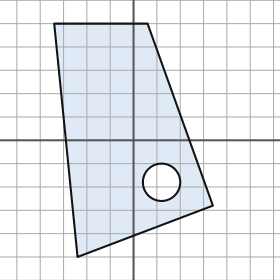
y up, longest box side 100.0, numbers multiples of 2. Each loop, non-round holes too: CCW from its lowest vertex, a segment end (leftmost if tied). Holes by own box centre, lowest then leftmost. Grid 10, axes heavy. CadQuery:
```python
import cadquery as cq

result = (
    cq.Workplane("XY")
    .moveTo(-24.0, -50.0)
    .lineTo(34.0, -28.0)
    .lineTo(6.0, 50.0)
    .lineTo(-34.0, 50.0)
    .close()
    .moveTo(12.0, -18.0)
    .circle(8.0)
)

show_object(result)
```